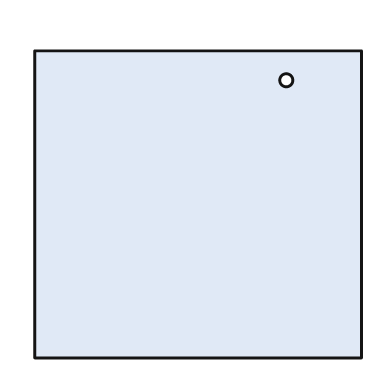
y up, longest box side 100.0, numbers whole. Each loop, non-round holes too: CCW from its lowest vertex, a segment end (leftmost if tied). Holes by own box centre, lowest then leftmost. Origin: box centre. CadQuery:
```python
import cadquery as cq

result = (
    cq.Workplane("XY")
    .moveTo(-50.0, -47.0)
    .lineTo(50.0, -47.0)
    .lineTo(50.0, 47.0)
    .lineTo(-50.0, 47.0)
    .close()
    .moveTo(27.0, 38.0)
    .circle(2.0)
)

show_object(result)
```